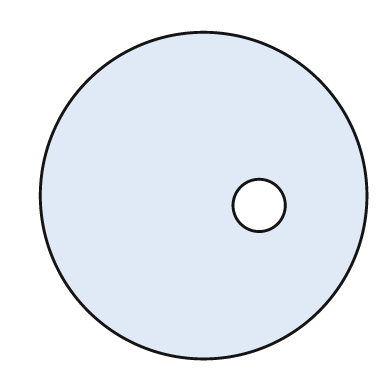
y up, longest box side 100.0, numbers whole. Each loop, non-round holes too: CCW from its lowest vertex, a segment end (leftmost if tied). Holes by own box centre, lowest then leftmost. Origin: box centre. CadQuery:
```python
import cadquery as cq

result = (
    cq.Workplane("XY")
    .moveTo(0.0, 0.0)
    .circle(50.0)
    .moveTo(17.0, -3.0)
    .circle(8.0)
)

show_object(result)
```